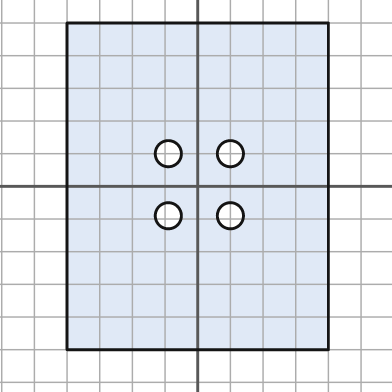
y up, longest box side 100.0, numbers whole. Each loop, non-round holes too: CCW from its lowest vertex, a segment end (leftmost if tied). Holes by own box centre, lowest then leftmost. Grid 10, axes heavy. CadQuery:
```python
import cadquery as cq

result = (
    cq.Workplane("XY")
    .moveTo(-40.0, -50.0)
    .lineTo(40.0, -50.0)
    .lineTo(40.0, 50.0)
    .lineTo(-40.0, 50.0)
    .close()
    .moveTo(-9.0, -9.0)
    .circle(4.0)
    .moveTo(10.0, -9.0)
    .circle(4.0)
    .moveTo(-9.0, 10.0)
    .circle(4.0)
    .moveTo(10.0, 10.0)
    .circle(4.0)
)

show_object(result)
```